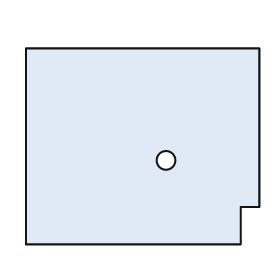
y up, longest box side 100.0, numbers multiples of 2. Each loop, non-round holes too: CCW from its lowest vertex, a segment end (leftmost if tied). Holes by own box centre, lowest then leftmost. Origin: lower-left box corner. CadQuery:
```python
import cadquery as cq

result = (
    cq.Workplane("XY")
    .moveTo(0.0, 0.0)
    .lineTo(92.0, 0.0)
    .lineTo(92.0, 16.0)
    .lineTo(100.0, 16.0)
    .lineTo(100.0, 84.0)
    .lineTo(0.0, 84.0)
    .close()
    .moveTo(60.0, 36.0)
    .circle(4.0)
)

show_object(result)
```